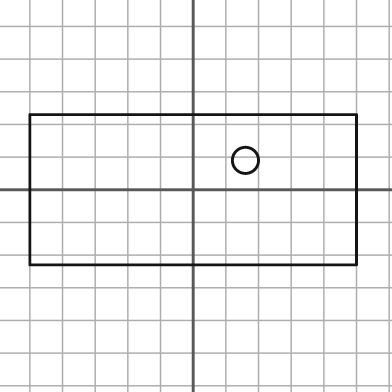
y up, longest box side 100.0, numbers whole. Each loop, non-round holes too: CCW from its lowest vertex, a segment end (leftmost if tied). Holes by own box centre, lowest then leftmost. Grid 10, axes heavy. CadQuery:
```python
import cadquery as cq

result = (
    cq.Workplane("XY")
    .moveTo(-50.0, -23.0)
    .lineTo(50.0, -23.0)
    .lineTo(50.0, 23.0)
    .lineTo(-50.0, 23.0)
    .close()
    .moveTo(16.0, 9.0)
    .circle(4.0)
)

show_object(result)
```